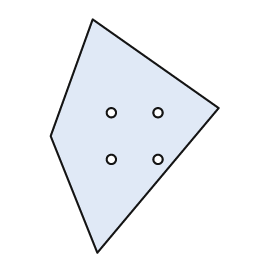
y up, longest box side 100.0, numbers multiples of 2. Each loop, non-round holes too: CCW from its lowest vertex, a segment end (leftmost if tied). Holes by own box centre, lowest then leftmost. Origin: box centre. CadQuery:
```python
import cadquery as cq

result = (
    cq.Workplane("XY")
    .moveTo(-16.0, -50.0)
    .lineTo(36.0, 12.0)
    .lineTo(-18.0, 50.0)
    .lineTo(-36.0, 0.0)
    .close()
    .moveTo(-10.0, -10.0)
    .circle(2.0)
    .moveTo(10.0, -10.0)
    .circle(2.0)
    .moveTo(-10.0, 10.0)
    .circle(2.0)
    .moveTo(10.0, 10.0)
    .circle(2.0)
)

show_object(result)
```